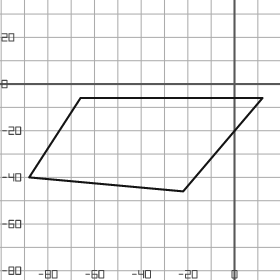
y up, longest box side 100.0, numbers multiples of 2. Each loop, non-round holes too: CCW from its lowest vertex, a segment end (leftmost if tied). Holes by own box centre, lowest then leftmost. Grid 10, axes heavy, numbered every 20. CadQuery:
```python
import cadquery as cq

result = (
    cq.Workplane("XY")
    .moveTo(-22.0, -46.0)
    .lineTo(12.0, -6.0)
    .lineTo(-66.0, -6.0)
    .lineTo(-88.0, -40.0)
    .close()
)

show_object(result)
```